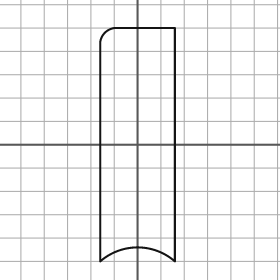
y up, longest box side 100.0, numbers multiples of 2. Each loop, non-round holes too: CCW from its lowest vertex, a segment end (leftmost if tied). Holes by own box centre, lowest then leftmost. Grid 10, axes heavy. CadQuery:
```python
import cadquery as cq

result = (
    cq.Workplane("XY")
    .moveTo(-16.0, -50.0)
    .threePointArc((0.0, -44.0), (16.0, -50.0))
    .lineTo(16.0, 50.0)
    .lineTo(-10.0, 50.0)
    .threePointArc((-14.0, 48.0), (-16.0, 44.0))
    .close()
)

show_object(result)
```